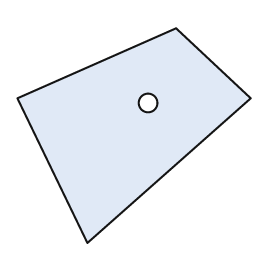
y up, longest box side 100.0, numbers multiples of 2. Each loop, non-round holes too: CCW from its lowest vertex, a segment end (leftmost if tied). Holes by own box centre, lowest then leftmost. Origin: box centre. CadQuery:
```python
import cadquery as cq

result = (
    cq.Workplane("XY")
    .moveTo(-20.0, -46.0)
    .lineTo(50.0, 16.0)
    .lineTo(18.0, 46.0)
    .lineTo(-50.0, 16.0)
    .close()
    .moveTo(6.0, 14.0)
    .circle(4.0)
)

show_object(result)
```